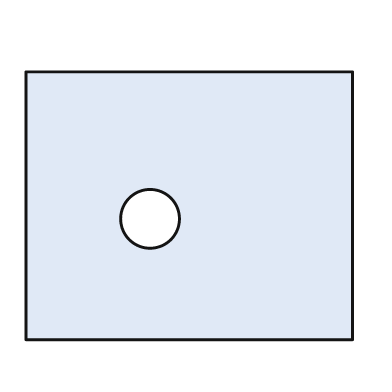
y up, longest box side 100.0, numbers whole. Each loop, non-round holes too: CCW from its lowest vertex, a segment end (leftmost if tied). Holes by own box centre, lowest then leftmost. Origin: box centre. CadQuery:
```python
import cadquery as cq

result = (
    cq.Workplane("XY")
    .moveTo(-50.0, -41.0)
    .lineTo(50.0, -41.0)
    .lineTo(50.0, 41.0)
    .lineTo(-50.0, 41.0)
    .close()
    .moveTo(-12.0, -4.0)
    .circle(9.0)
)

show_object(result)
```